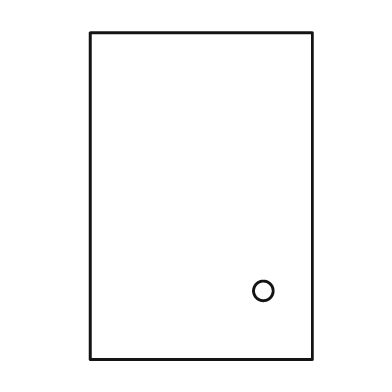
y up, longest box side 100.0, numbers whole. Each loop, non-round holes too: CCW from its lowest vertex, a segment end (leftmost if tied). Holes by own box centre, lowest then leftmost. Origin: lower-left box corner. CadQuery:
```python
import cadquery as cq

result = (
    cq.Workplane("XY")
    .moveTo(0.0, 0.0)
    .lineTo(68.0, 0.0)
    .lineTo(68.0, 100.0)
    .lineTo(0.0, 100.0)
    .close()
    .moveTo(53.0, 21.0)
    .circle(3.0)
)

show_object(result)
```